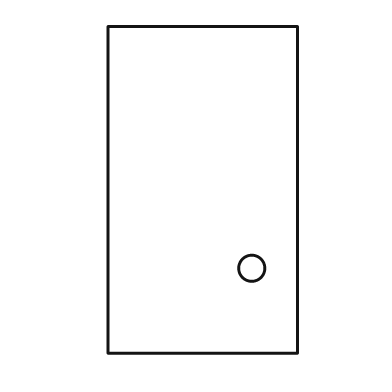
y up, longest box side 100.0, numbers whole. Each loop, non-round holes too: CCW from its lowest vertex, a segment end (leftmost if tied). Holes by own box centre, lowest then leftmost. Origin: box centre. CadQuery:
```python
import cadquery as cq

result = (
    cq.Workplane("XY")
    .moveTo(-29.0, -50.0)
    .lineTo(29.0, -50.0)
    .lineTo(29.0, 50.0)
    .lineTo(-29.0, 50.0)
    .close()
    .moveTo(15.0, -24.0)
    .circle(4.0)
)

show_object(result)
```